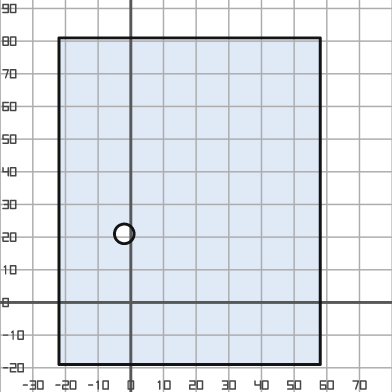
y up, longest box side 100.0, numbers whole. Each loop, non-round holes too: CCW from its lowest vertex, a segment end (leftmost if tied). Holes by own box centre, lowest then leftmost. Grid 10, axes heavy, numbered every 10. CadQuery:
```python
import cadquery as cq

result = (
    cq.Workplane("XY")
    .moveTo(-22.0, -19.0)
    .lineTo(58.0, -19.0)
    .lineTo(58.0, 81.0)
    .lineTo(-22.0, 81.0)
    .close()
    .moveTo(-2.0, 21.0)
    .circle(3.0)
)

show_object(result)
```